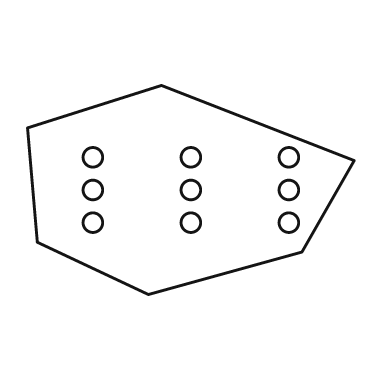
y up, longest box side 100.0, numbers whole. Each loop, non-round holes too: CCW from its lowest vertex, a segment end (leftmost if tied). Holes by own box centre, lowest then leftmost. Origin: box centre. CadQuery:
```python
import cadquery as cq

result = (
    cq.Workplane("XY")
    .moveTo(-13.0, -32.0)
    .lineTo(34.0, -19.0)
    .lineTo(50.0, 9.0)
    .lineTo(-9.0, 32.0)
    .lineTo(-50.0, 19.0)
    .lineTo(-47.0, -16.0)
    .close()
    .moveTo(-30.0, -10.0)
    .circle(3.0)
    .moveTo(0.0, -10.0)
    .circle(3.0)
    .moveTo(30.0, -10.0)
    .circle(3.0)
    .moveTo(-30.0, 0.0)
    .circle(3.0)
    .moveTo(0.0, 0.0)
    .circle(3.0)
    .moveTo(30.0, 0.0)
    .circle(3.0)
    .moveTo(-30.0, 10.0)
    .circle(3.0)
    .moveTo(0.0, 10.0)
    .circle(3.0)
    .moveTo(30.0, 10.0)
    .circle(3.0)
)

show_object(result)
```